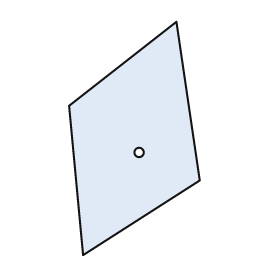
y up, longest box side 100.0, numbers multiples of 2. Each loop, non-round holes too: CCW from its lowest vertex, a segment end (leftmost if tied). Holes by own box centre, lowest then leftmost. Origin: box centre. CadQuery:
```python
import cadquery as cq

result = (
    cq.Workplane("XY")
    .moveTo(-22.0, -50.0)
    .lineTo(28.0, -18.0)
    .lineTo(18.0, 50.0)
    .lineTo(-28.0, 14.0)
    .close()
    .moveTo(2.0, -6.0)
    .circle(2.0)
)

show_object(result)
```